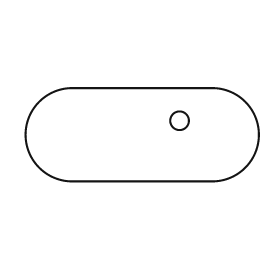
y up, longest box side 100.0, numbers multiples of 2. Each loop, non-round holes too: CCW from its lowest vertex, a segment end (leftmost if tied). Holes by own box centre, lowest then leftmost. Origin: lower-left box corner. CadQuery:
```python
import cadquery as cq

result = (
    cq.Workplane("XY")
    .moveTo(20.0, 0.0)
    .lineTo(80.0, 0.0)
    .threePointArc((100.0, 20.0), (80.0, 40.0))
    .lineTo(20.0, 40.0)
    .threePointArc((0.0, 20.0), (20.0, 0.0))
    .close()
    .moveTo(66.0, 26.0)
    .circle(4.0)
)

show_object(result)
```